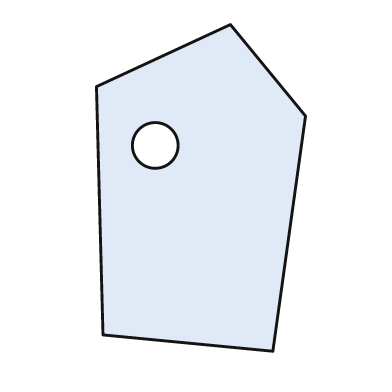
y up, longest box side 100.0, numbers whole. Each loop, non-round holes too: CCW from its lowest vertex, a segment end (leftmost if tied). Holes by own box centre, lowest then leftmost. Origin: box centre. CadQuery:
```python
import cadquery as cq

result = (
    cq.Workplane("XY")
    .moveTo(22.0, -50.0)
    .lineTo(32.0, 22.0)
    .lineTo(9.0, 50.0)
    .lineTo(-32.0, 31.0)
    .lineTo(-30.0, -45.0)
    .close()
    .moveTo(-14.0, 13.0)
    .circle(7.0)
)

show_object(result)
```